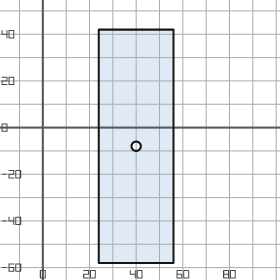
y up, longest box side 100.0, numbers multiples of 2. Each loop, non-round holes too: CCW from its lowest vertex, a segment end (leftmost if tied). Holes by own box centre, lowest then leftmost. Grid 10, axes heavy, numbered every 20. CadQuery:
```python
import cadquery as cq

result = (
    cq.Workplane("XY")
    .moveTo(24.0, -58.0)
    .lineTo(56.0, -58.0)
    .lineTo(56.0, 42.0)
    .lineTo(24.0, 42.0)
    .close()
    .moveTo(40.0, -8.0)
    .circle(2.0)
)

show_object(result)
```